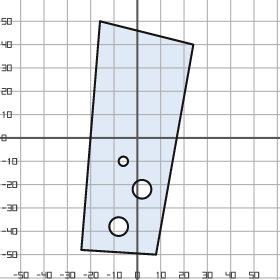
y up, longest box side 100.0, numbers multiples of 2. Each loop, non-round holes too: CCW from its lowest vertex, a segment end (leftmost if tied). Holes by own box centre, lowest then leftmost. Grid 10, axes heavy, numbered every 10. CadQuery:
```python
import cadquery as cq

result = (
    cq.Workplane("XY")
    .moveTo(8.0, -50.0)
    .lineTo(24.0, 40.0)
    .lineTo(-16.0, 50.0)
    .lineTo(-24.0, -48.0)
    .close()
    .moveTo(-8.0, -38.0)
    .circle(4.0)
    .moveTo(2.0, -22.0)
    .circle(4.0)
    .moveTo(-6.0, -10.0)
    .circle(2.0)
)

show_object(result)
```